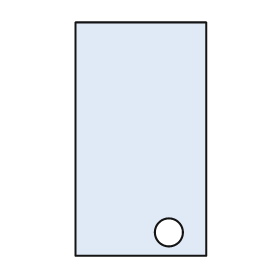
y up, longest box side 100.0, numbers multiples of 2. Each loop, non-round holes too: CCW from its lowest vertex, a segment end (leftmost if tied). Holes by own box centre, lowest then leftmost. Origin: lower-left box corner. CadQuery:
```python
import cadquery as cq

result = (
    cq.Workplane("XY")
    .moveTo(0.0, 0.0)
    .lineTo(56.0, 0.0)
    .lineTo(56.0, 100.0)
    .lineTo(0.0, 100.0)
    .close()
    .moveTo(40.0, 10.0)
    .circle(6.0)
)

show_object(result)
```